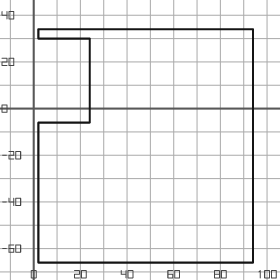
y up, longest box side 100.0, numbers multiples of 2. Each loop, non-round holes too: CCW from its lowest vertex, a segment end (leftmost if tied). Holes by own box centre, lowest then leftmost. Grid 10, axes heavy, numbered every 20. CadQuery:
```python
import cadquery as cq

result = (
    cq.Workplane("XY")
    .moveTo(2.0, -66.0)
    .lineTo(94.0, -66.0)
    .lineTo(94.0, 34.0)
    .lineTo(2.0, 34.0)
    .lineTo(2.0, 30.0)
    .lineTo(24.0, 30.0)
    .lineTo(24.0, -6.0)
    .lineTo(2.0, -6.0)
    .close()
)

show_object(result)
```